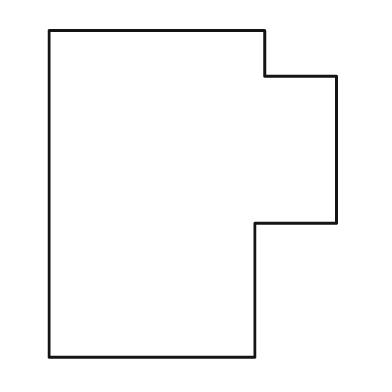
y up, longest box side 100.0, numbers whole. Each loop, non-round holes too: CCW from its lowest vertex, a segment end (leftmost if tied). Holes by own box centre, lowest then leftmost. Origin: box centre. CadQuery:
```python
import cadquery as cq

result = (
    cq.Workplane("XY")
    .moveTo(-44.0, -50.0)
    .lineTo(19.0, -50.0)
    .lineTo(19.0, -9.0)
    .lineTo(44.0, -9.0)
    .lineTo(44.0, 36.0)
    .lineTo(22.0, 36.0)
    .lineTo(22.0, 50.0)
    .lineTo(-44.0, 50.0)
    .close()
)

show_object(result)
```